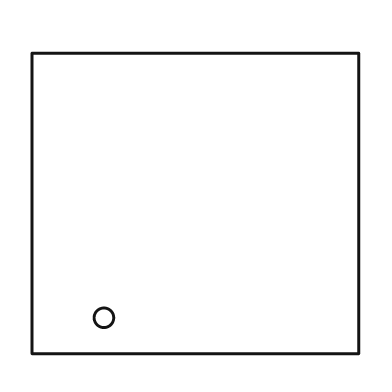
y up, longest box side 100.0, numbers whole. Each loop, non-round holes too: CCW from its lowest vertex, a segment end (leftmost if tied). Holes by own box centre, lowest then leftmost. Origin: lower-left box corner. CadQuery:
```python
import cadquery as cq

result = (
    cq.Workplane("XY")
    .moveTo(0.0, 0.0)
    .lineTo(100.0, 0.0)
    .lineTo(100.0, 92.0)
    .lineTo(0.0, 92.0)
    .close()
    .moveTo(22.0, 11.0)
    .circle(3.0)
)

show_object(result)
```